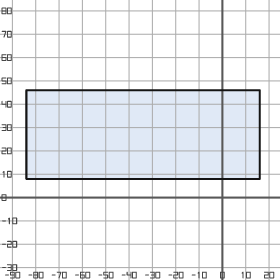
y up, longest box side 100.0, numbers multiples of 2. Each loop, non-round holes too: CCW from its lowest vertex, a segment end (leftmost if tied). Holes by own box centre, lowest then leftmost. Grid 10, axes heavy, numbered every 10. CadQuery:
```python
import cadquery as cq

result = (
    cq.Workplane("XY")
    .moveTo(-84.0, 8.0)
    .lineTo(16.0, 8.0)
    .lineTo(16.0, 46.0)
    .lineTo(-84.0, 46.0)
    .close()
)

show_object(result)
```